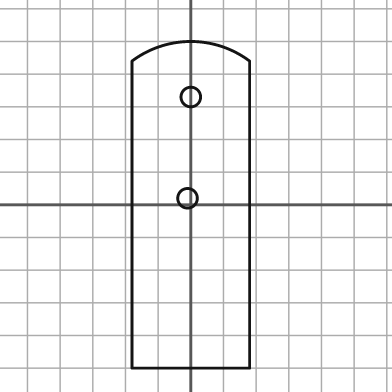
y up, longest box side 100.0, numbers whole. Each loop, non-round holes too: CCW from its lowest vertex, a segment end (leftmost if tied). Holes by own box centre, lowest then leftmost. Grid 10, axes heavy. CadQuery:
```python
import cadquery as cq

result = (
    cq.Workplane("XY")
    .moveTo(-18.0, -50.0)
    .lineTo(18.0, -50.0)
    .lineTo(18.0, 44.0)
    .threePointArc((0.0, 50.0), (-18.0, 44.0))
    .close()
    .moveTo(-1.0, 2.0)
    .circle(3.0)
    .moveTo(0.0, 33.0)
    .circle(3.0)
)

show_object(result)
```